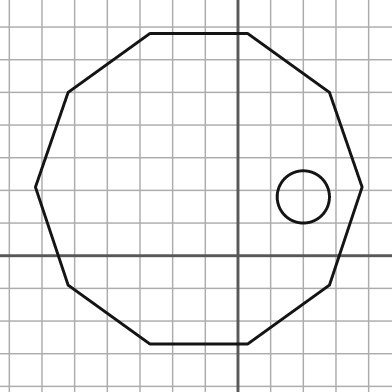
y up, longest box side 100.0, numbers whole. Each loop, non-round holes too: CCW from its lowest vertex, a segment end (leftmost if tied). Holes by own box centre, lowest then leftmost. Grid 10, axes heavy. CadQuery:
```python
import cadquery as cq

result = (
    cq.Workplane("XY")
    .moveTo(-27.0, -27.0)
    .lineTo(3.0, -27.0)
    .lineTo(28.0, -9.0)
    .lineTo(38.0, 21.0)
    .lineTo(28.0, 50.0)
    .lineTo(3.0, 68.0)
    .lineTo(-27.0, 68.0)
    .lineTo(-52.0, 50.0)
    .lineTo(-62.0, 21.0)
    .lineTo(-52.0, -9.0)
    .close()
    .moveTo(20.0, 18.0)
    .circle(8.0)
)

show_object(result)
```